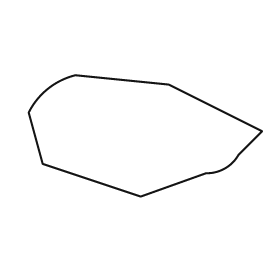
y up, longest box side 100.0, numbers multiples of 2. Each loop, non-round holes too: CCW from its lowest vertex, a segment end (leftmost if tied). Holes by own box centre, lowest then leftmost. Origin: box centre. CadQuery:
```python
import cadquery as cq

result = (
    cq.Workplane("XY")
    .moveTo(-2.0, -26.0)
    .lineTo(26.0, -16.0)
    .threePointArc((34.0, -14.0), (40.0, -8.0))
    .lineTo(50.0, 2.0)
    .lineTo(10.0, 22.0)
    .lineTo(-30.0, 26.0)
    .threePointArc((-42.0, 20.0), (-50.0, 10.0))
    .lineTo(-44.0, -12.0)
    .close()
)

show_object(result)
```